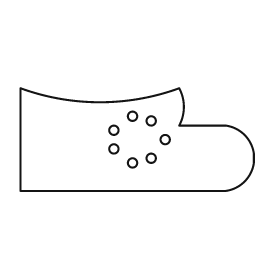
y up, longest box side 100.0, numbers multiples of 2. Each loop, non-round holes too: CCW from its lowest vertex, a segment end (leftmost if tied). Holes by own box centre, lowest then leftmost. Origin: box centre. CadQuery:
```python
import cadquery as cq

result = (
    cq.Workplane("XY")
    .moveTo(-50.0, -22.0)
    .lineTo(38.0, -22.0)
    .threePointArc((46.0, -18.0), (50.0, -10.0))
    .lineTo(50.0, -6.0)
    .threePointArc((46.0, 2.0), (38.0, 6.0))
    .lineTo(18.0, 6.0)
    .threePointArc((20.0, 14.0), (18.0, 22.0))
    .threePointArc((-16.0, 16.0), (-50.0, 22.0))
    .close()
    .moveTo(-2.0, -10.0)
    .circle(2.0)
    .moveTo(6.0, -8.0)
    .circle(2.0)
    .moveTo(-10.0, -4.0)
    .circle(2.0)
    .moveTo(12.0, 0.0)
    .circle(2.0)
    .moveTo(-10.0, 4.0)
    .circle(2.0)
    .moveTo(6.0, 8.0)
    .circle(2.0)
    .moveTo(-2.0, 10.0)
    .circle(2.0)
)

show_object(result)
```